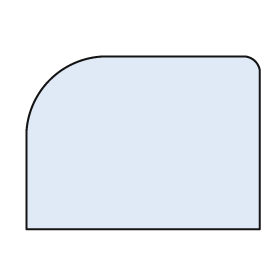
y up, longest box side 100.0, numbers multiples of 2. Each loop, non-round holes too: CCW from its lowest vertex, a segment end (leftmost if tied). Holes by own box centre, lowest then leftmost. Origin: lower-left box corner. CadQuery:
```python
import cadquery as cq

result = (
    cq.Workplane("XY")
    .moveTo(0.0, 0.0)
    .lineTo(100.0, 0.0)
    .lineTo(100.0, 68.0)
    .threePointArc((98.0, 72.0), (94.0, 74.0))
    .lineTo(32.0, 74.0)
    .threePointArc((10.0, 64.0), (0.0, 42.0))
    .close()
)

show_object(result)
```